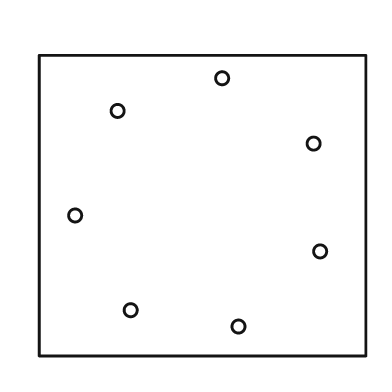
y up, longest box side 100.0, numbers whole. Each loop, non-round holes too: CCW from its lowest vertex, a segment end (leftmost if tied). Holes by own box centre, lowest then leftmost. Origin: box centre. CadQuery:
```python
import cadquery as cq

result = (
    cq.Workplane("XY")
    .moveTo(-50.0, -46.0)
    .lineTo(50.0, -46.0)
    .lineTo(50.0, 46.0)
    .lineTo(-50.0, 46.0)
    .close()
    .moveTo(11.0, -37.0)
    .circle(2.0)
    .moveTo(-22.0, -32.0)
    .circle(2.0)
    .moveTo(36.0, -14.0)
    .circle(2.0)
    .moveTo(-39.0, -3.0)
    .circle(2.0)
    .moveTo(34.0, 19.0)
    .circle(2.0)
    .moveTo(-26.0, 29.0)
    .circle(2.0)
    .moveTo(6.0, 39.0)
    .circle(2.0)
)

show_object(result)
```